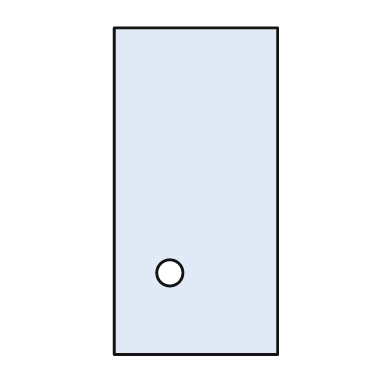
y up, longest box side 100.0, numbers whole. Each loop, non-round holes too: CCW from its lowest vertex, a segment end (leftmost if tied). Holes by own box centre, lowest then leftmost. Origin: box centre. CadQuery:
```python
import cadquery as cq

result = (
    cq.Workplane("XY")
    .moveTo(-25.0, -50.0)
    .lineTo(25.0, -50.0)
    .lineTo(25.0, 50.0)
    .lineTo(-25.0, 50.0)
    .close()
    .moveTo(-8.0, -25.0)
    .circle(4.0)
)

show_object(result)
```